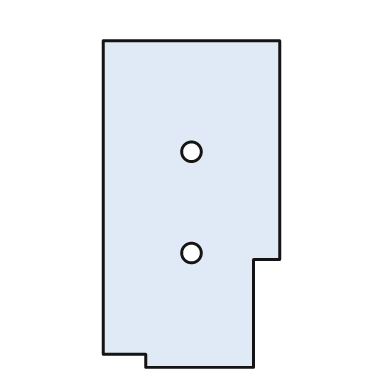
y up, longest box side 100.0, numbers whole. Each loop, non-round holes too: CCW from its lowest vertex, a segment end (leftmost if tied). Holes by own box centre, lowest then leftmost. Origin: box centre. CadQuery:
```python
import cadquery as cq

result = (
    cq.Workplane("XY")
    .moveTo(-14.0, -50.0)
    .lineTo(19.0, -50.0)
    .lineTo(19.0, -17.0)
    .lineTo(27.0, -17.0)
    .lineTo(27.0, 50.0)
    .lineTo(-27.0, 50.0)
    .lineTo(-27.0, -46.0)
    .lineTo(-14.0, -46.0)
    .close()
    .moveTo(0.0, -15.0)
    .circle(3.0)
    .moveTo(0.0, 16.0)
    .circle(3.0)
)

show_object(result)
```